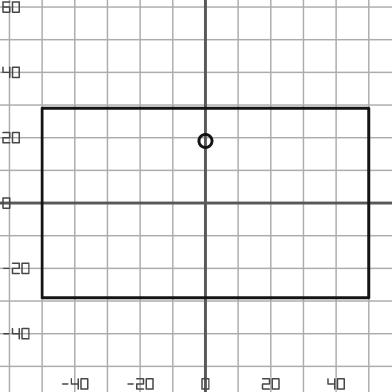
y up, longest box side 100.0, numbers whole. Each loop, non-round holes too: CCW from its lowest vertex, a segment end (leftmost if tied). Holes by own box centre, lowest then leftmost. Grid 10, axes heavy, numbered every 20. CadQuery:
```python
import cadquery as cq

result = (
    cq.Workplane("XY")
    .moveTo(-50.0, -29.0)
    .lineTo(50.0, -29.0)
    .lineTo(50.0, 29.0)
    .lineTo(-50.0, 29.0)
    .close()
    .moveTo(0.0, 19.0)
    .circle(2.0)
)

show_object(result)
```